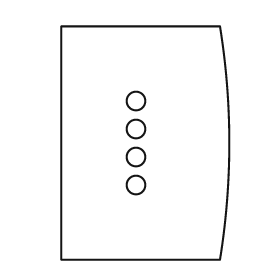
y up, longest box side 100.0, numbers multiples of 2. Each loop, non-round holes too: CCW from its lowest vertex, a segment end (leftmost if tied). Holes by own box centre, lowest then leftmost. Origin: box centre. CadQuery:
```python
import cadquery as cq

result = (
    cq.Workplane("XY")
    .moveTo(-36.0, -50.0)
    .lineTo(32.0, -50.0)
    .threePointArc((36.0, 0.0), (32.0, 50.0))
    .lineTo(-36.0, 50.0)
    .close()
    .moveTo(-4.0, -18.0)
    .circle(4.0)
    .moveTo(-4.0, -6.0)
    .circle(4.0)
    .moveTo(-4.0, 6.0)
    .circle(4.0)
    .moveTo(-4.0, 18.0)
    .circle(4.0)
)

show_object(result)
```